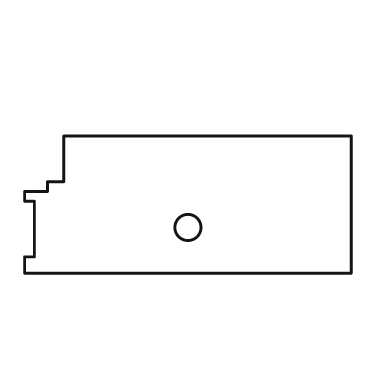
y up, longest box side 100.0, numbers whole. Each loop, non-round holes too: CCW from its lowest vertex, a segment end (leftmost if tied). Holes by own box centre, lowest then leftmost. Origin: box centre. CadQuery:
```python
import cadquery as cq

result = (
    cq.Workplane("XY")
    .moveTo(-50.0, -21.0)
    .lineTo(50.0, -21.0)
    .lineTo(50.0, 21.0)
    .lineTo(-38.0, 21.0)
    .lineTo(-38.0, 7.0)
    .lineTo(-43.0, 7.0)
    .lineTo(-43.0, 4.0)
    .lineTo(-50.0, 4.0)
    .lineTo(-50.0, 1.0)
    .lineTo(-47.0, 1.0)
    .lineTo(-47.0, -16.0)
    .lineTo(-50.0, -16.0)
    .close()
    .moveTo(0.0, -7.0)
    .circle(4.0)
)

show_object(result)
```